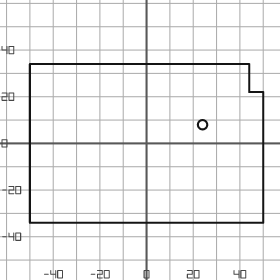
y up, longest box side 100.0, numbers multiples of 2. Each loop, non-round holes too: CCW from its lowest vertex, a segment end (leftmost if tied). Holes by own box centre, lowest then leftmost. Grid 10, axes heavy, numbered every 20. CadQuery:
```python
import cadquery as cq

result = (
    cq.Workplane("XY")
    .moveTo(-50.0, -34.0)
    .lineTo(50.0, -34.0)
    .lineTo(50.0, 22.0)
    .lineTo(44.0, 22.0)
    .lineTo(44.0, 34.0)
    .lineTo(-50.0, 34.0)
    .close()
    .moveTo(24.0, 8.0)
    .circle(2.0)
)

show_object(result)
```